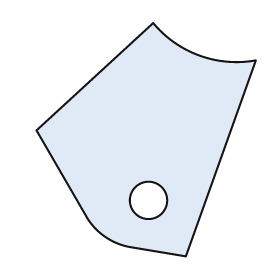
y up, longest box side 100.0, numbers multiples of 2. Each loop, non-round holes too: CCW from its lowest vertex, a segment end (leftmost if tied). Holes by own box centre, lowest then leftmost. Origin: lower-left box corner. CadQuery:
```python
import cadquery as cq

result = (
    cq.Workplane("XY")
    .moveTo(64.0, 0.0)
    .lineTo(94.0, 84.0)
    .threePointArc((70.0, 86.0), (50.0, 100.0))
    .lineTo(0.0, 54.0)
    .lineTo(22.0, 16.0)
    .threePointArc((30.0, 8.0), (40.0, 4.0))
    .close()
    .moveTo(48.0, 24.0)
    .circle(8.0)
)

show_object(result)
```